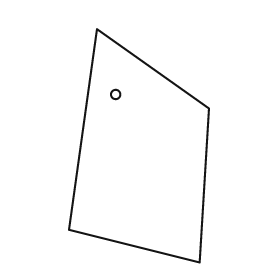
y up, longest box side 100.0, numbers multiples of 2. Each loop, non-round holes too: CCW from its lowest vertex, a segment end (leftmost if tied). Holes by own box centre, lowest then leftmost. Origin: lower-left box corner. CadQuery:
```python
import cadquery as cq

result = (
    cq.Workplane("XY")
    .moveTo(56.0, 0.0)
    .lineTo(60.0, 66.0)
    .lineTo(12.0, 100.0)
    .lineTo(0.0, 14.0)
    .close()
    .moveTo(20.0, 72.0)
    .circle(2.0)
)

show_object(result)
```